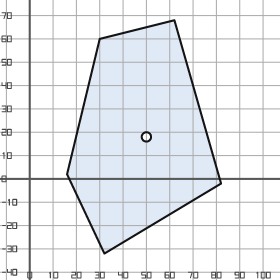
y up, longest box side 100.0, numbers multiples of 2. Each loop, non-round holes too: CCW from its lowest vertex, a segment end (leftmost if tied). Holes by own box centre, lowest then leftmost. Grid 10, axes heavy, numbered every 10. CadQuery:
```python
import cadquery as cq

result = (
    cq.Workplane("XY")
    .moveTo(32.0, -32.0)
    .lineTo(82.0, -2.0)
    .lineTo(62.0, 68.0)
    .lineTo(30.0, 60.0)
    .lineTo(16.0, 2.0)
    .close()
    .moveTo(50.0, 18.0)
    .circle(2.0)
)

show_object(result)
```